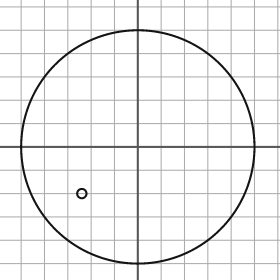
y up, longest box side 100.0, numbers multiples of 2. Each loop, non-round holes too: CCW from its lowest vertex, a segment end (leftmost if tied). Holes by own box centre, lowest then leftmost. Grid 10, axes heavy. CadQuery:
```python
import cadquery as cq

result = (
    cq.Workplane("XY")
    .moveTo(0.0, 0.0)
    .circle(50.0)
    .moveTo(-24.0, -20.0)
    .circle(2.0)
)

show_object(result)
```